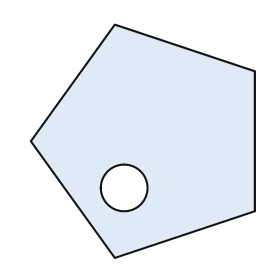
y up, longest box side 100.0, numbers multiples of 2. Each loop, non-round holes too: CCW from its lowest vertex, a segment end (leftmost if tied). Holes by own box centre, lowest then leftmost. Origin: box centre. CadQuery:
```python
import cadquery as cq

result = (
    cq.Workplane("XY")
    .moveTo(-12.0, -50.0)
    .lineTo(48.0, -30.0)
    .lineTo(48.0, 30.0)
    .lineTo(-12.0, 50.0)
    .lineTo(-48.0, 0.0)
    .close()
    .moveTo(-8.0, -20.0)
    .circle(10.0)
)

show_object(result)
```